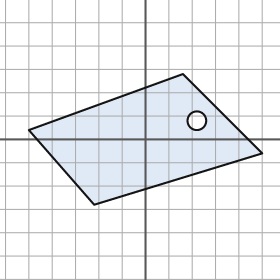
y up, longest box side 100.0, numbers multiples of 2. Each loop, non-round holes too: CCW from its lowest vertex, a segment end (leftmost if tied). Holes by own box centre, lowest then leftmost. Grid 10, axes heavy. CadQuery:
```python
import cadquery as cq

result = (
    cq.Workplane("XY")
    .moveTo(-22.0, -28.0)
    .lineTo(50.0, -6.0)
    .lineTo(16.0, 28.0)
    .lineTo(-50.0, 4.0)
    .close()
    .moveTo(22.0, 8.0)
    .circle(4.0)
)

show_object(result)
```